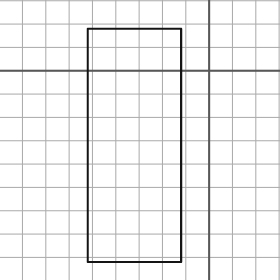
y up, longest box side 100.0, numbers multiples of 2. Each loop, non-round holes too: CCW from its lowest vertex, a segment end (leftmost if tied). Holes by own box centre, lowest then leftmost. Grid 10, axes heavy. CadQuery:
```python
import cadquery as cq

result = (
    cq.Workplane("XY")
    .moveTo(-52.0, -82.0)
    .lineTo(-12.0, -82.0)
    .lineTo(-12.0, 18.0)
    .lineTo(-52.0, 18.0)
    .close()
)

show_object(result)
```